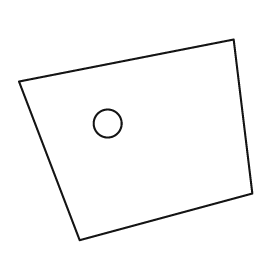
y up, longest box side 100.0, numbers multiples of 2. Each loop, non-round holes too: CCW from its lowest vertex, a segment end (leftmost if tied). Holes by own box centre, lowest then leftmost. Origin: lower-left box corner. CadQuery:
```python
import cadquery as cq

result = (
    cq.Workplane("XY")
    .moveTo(26.0, 0.0)
    .lineTo(100.0, 20.0)
    .lineTo(92.0, 86.0)
    .lineTo(0.0, 68.0)
    .close()
    .moveTo(38.0, 50.0)
    .circle(6.0)
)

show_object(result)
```